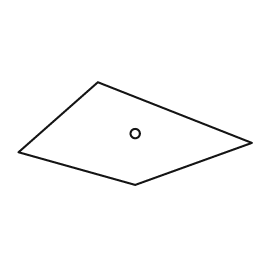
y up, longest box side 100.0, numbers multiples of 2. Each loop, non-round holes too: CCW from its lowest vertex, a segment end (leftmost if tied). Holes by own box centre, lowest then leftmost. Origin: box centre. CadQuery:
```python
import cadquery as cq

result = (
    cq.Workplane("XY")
    .moveTo(0.0, -22.0)
    .lineTo(50.0, -4.0)
    .lineTo(-16.0, 22.0)
    .lineTo(-50.0, -8.0)
    .close()
    .moveTo(0.0, 0.0)
    .circle(2.0)
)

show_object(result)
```